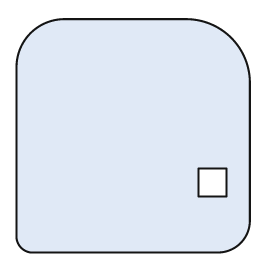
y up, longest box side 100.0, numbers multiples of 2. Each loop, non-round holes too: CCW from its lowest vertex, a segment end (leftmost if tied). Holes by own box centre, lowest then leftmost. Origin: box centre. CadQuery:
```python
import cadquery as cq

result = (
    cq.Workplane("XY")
    .moveTo(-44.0, -50.0)
    .lineTo(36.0, -50.0)
    .threePointArc((46.0, -46.0), (50.0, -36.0))
    .lineTo(50.0, 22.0)
    .threePointArc((42.0, 42.0), (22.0, 50.0))
    .lineTo(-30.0, 50.0)
    .threePointArc((-44.0, 44.0), (-50.0, 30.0))
    .lineTo(-50.0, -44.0)
    .threePointArc((-48.0, -48.0), (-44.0, -50.0))
    .close()
    .moveTo(28.0, -26.0)
    .lineTo(40.0, -26.0)
    .lineTo(40.0, -14.0)
    .lineTo(28.0, -14.0)
    .close()
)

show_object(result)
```